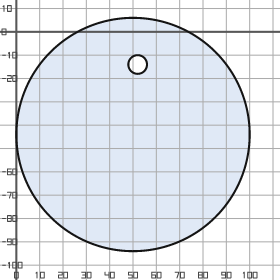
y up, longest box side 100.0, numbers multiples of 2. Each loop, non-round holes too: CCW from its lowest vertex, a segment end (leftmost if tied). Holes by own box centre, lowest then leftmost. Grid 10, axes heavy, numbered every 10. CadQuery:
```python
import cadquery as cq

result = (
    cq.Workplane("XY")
    .moveTo(50.0, -44.0)
    .circle(50.0)
    .moveTo(52.0, -14.0)
    .circle(4.0)
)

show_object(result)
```